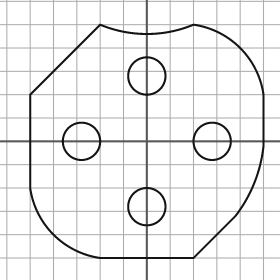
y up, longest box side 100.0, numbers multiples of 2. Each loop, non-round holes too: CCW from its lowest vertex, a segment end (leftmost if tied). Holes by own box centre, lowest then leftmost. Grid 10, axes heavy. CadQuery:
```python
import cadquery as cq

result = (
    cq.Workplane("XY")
    .moveTo(-20.0, -50.0)
    .lineTo(20.0, -50.0)
    .lineTo(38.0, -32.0)
    .threePointArc((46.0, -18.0), (50.0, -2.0))
    .lineTo(50.0, 20.0)
    .threePointArc((40.0, 40.0), (20.0, 50.0))
    .threePointArc((0.0, 46.0), (-20.0, 50.0))
    .lineTo(-50.0, 20.0)
    .lineTo(-50.0, -20.0)
    .threePointArc((-40.0, -40.0), (-20.0, -50.0))
    .close()
    .moveTo(0.0, -28.0)
    .circle(8.0)
    .moveTo(-28.0, 0.0)
    .circle(8.0)
    .moveTo(28.0, 0.0)
    .circle(8.0)
    .moveTo(0.0, 28.0)
    .circle(8.0)
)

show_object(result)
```